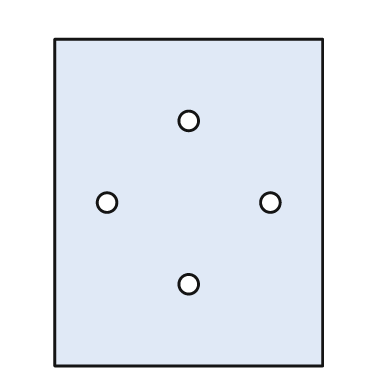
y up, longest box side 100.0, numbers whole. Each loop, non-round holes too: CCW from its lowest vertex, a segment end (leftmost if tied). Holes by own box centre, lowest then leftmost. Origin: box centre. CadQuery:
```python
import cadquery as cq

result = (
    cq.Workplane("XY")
    .moveTo(-41.0, -50.0)
    .lineTo(41.0, -50.0)
    .lineTo(41.0, 50.0)
    .lineTo(-41.0, 50.0)
    .close()
    .moveTo(0.0, -25.0)
    .circle(3.0)
    .moveTo(-25.0, 0.0)
    .circle(3.0)
    .moveTo(25.0, 0.0)
    .circle(3.0)
    .moveTo(0.0, 25.0)
    .circle(3.0)
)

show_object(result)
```